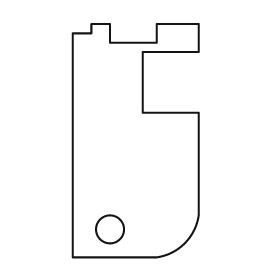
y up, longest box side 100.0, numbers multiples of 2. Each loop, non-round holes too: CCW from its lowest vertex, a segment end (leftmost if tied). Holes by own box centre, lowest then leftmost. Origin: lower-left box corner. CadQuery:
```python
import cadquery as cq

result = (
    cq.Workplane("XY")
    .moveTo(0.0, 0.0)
    .lineTo(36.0, 0.0)
    .threePointArc((48.0, 6.0), (54.0, 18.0))
    .lineTo(54.0, 62.0)
    .lineTo(30.0, 62.0)
    .lineTo(30.0, 88.0)
    .lineTo(54.0, 88.0)
    .lineTo(54.0, 100.0)
    .lineTo(36.0, 100.0)
    .lineTo(36.0, 92.0)
    .lineTo(16.0, 92.0)
    .lineTo(16.0, 100.0)
    .lineTo(8.0, 100.0)
    .lineTo(8.0, 96.0)
    .lineTo(0.0, 96.0)
    .close()
    .moveTo(16.0, 12.0)
    .circle(6.0)
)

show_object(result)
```